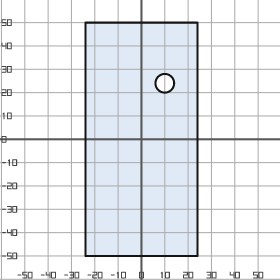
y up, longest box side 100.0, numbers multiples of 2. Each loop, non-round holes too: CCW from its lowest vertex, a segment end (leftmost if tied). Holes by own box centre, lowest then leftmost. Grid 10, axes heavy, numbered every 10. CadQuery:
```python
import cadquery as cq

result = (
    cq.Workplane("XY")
    .moveTo(-24.0, -50.0)
    .lineTo(24.0, -50.0)
    .lineTo(24.0, 50.0)
    .lineTo(-24.0, 50.0)
    .close()
    .moveTo(10.0, 24.0)
    .circle(4.0)
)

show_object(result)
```